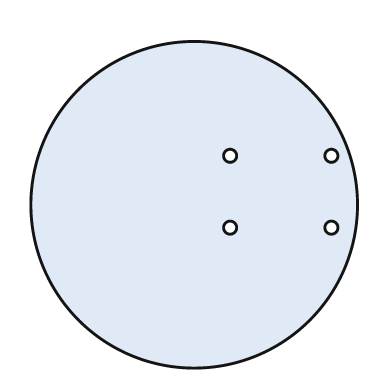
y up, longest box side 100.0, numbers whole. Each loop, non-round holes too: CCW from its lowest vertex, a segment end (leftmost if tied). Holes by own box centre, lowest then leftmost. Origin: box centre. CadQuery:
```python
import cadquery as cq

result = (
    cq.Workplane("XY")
    .moveTo(0.0, 0.0)
    .circle(50.0)
    .moveTo(11.0, -7.0)
    .circle(2.0)
    .moveTo(42.0, -7.0)
    .circle(2.0)
    .moveTo(11.0, 15.0)
    .circle(2.0)
    .moveTo(42.0, 15.0)
    .circle(2.0)
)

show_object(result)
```